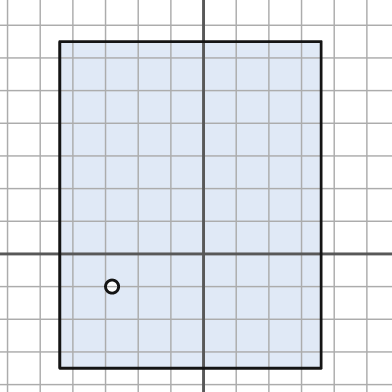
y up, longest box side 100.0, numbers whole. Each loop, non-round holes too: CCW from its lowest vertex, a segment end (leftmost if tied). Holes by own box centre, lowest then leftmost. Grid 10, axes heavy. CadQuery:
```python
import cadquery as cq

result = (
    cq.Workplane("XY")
    .moveTo(-44.0, -35.0)
    .lineTo(36.0, -35.0)
    .lineTo(36.0, 65.0)
    .lineTo(-44.0, 65.0)
    .close()
    .moveTo(-28.0, -10.0)
    .circle(2.0)
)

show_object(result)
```